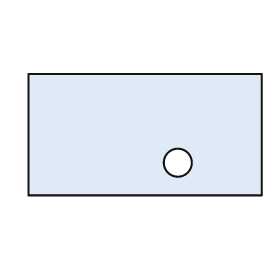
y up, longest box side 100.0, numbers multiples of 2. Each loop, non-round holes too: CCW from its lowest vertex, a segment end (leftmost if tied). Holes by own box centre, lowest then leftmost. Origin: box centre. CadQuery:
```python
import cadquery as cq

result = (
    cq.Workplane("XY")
    .moveTo(-50.0, -26.0)
    .lineTo(50.0, -26.0)
    .lineTo(50.0, 26.0)
    .lineTo(-50.0, 26.0)
    .close()
    .moveTo(14.0, -12.0)
    .circle(6.0)
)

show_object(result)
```